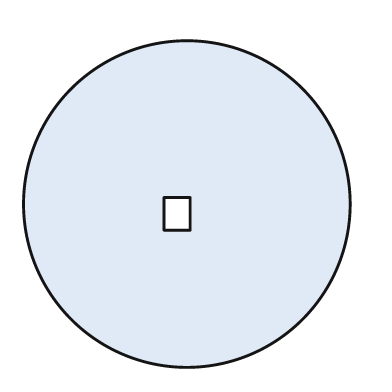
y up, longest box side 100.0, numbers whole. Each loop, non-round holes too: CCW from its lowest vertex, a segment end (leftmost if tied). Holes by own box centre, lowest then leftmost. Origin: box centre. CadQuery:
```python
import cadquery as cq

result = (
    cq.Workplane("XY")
    .moveTo(0.0, 0.0)
    .circle(50.0)
    .moveTo(-7.0, -8.0)
    .lineTo(1.0, -8.0)
    .lineTo(1.0, 2.0)
    .lineTo(-7.0, 2.0)
    .close()
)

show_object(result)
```